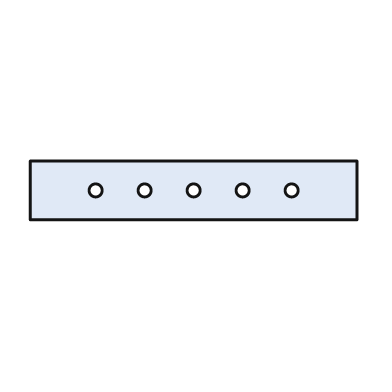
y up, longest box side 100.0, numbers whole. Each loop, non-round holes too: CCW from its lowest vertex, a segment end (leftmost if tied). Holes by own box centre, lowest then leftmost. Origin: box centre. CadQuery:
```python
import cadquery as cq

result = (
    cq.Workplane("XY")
    .moveTo(-50.0, -9.0)
    .lineTo(50.0, -9.0)
    .lineTo(50.0, 9.0)
    .lineTo(-50.0, 9.0)
    .close()
    .moveTo(-30.0, 0.0)
    .circle(2.0)
    .moveTo(-15.0, 0.0)
    .circle(2.0)
    .moveTo(0.0, 0.0)
    .circle(2.0)
    .moveTo(15.0, 0.0)
    .circle(2.0)
    .moveTo(30.0, 0.0)
    .circle(2.0)
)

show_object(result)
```